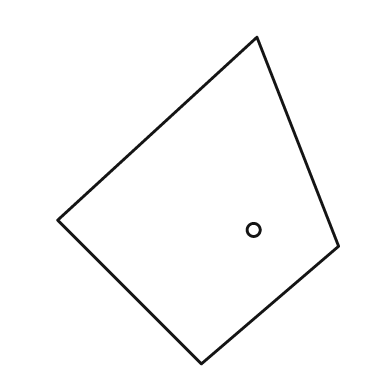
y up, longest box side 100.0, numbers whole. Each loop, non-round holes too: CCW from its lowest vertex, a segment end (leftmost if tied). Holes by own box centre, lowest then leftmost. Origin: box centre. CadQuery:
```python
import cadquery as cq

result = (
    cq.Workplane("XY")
    .moveTo(1.0, -50.0)
    .lineTo(43.0, -14.0)
    .lineTo(18.0, 50.0)
    .lineTo(-43.0, -6.0)
    .close()
    .moveTo(17.0, -9.0)
    .circle(2.0)
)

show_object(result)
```